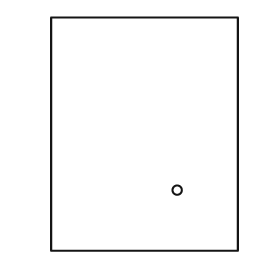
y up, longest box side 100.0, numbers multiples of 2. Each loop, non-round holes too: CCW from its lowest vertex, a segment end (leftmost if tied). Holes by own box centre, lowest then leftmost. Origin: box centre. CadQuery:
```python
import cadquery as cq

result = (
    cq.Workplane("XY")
    .moveTo(-40.0, -50.0)
    .lineTo(40.0, -50.0)
    .lineTo(40.0, 50.0)
    .lineTo(-40.0, 50.0)
    .close()
    .moveTo(14.0, -24.0)
    .circle(2.0)
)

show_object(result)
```